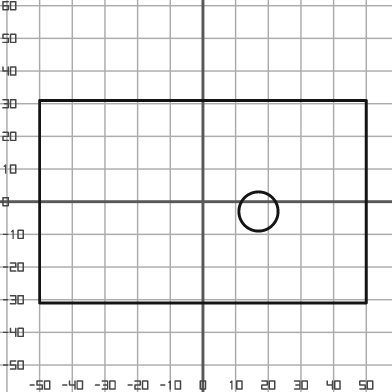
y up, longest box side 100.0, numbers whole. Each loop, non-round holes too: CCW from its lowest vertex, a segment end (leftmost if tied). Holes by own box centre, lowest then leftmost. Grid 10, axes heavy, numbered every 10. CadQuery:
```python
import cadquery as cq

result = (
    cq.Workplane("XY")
    .moveTo(-50.0, -31.0)
    .lineTo(50.0, -31.0)
    .lineTo(50.0, 31.0)
    .lineTo(-50.0, 31.0)
    .close()
    .moveTo(17.0, -3.0)
    .circle(6.0)
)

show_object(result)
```